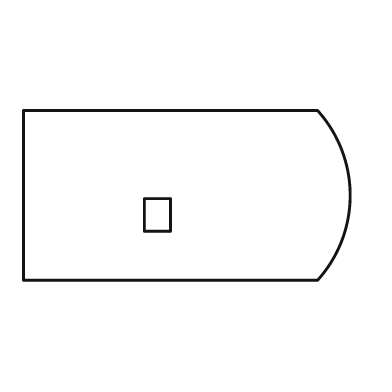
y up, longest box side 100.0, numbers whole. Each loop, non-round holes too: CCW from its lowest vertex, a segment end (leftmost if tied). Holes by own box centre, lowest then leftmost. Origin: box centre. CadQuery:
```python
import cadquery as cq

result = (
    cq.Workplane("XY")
    .moveTo(-50.0, -26.0)
    .lineTo(40.0, -26.0)
    .threePointArc((50.0, 0.0), (40.0, 26.0))
    .lineTo(-50.0, 26.0)
    .close()
    .moveTo(-13.0, -11.0)
    .lineTo(-5.0, -11.0)
    .lineTo(-5.0, -1.0)
    .lineTo(-13.0, -1.0)
    .close()
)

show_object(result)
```